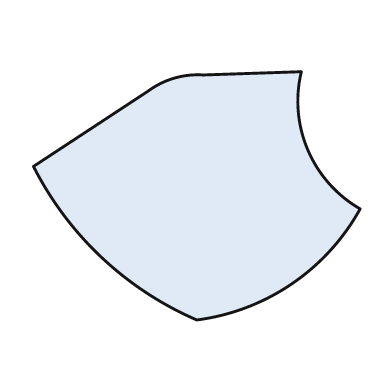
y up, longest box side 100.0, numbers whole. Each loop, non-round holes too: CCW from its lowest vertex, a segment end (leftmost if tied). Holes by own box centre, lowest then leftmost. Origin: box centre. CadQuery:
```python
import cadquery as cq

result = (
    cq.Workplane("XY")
    .moveTo(0.0, -38.0)
    .threePointArc((29.0, -27.0), (50.0, -4.0))
    .threePointArc((34.0, 14.0), (32.0, 38.0))
    .lineTo(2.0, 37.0)
    .threePointArc((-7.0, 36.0), (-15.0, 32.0))
    .lineTo(-50.0, 9.0)
    .threePointArc((-29.0, -19.0), (0.0, -38.0))
    .close()
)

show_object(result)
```